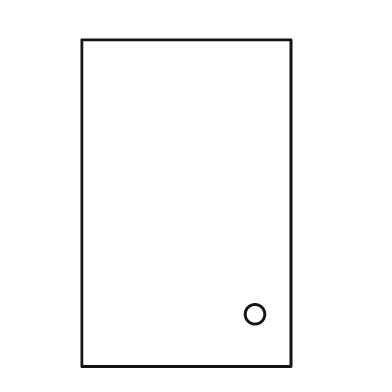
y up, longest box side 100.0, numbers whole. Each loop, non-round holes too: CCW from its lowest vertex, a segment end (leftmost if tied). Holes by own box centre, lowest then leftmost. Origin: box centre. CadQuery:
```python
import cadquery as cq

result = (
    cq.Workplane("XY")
    .moveTo(-32.0, -50.0)
    .lineTo(32.0, -50.0)
    .lineTo(32.0, 50.0)
    .lineTo(-32.0, 50.0)
    .close()
    .moveTo(21.0, -34.0)
    .circle(3.0)
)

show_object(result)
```